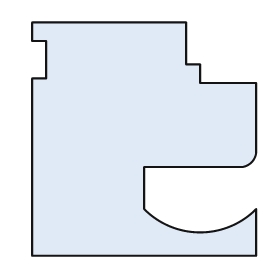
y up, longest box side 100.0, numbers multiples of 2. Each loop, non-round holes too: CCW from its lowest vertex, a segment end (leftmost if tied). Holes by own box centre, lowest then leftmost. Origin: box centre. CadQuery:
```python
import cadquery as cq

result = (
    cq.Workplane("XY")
    .moveTo(-48.0, -50.0)
    .lineTo(48.0, -50.0)
    .lineTo(48.0, -30.0)
    .threePointArc((24.0, -40.0), (0.0, -30.0))
    .lineTo(0.0, -12.0)
    .lineTo(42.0, -12.0)
    .threePointArc((46.0, -10.0), (48.0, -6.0))
    .lineTo(48.0, 24.0)
    .lineTo(24.0, 24.0)
    .lineTo(24.0, 32.0)
    .lineTo(18.0, 32.0)
    .lineTo(18.0, 50.0)
    .lineTo(-48.0, 50.0)
    .lineTo(-48.0, 42.0)
    .lineTo(-42.0, 42.0)
    .lineTo(-42.0, 26.0)
    .lineTo(-48.0, 26.0)
    .close()
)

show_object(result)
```